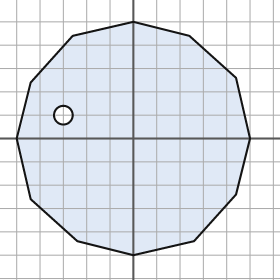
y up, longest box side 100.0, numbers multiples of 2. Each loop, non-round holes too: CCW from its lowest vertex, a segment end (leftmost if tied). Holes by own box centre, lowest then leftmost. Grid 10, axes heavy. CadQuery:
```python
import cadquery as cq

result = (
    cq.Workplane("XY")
    .moveTo(0.0, -50.0)
    .lineTo(26.0, -44.0)
    .lineTo(44.0, -24.0)
    .lineTo(50.0, 0.0)
    .lineTo(44.0, 26.0)
    .lineTo(24.0, 44.0)
    .lineTo(0.0, 50.0)
    .lineTo(-26.0, 44.0)
    .lineTo(-44.0, 24.0)
    .lineTo(-50.0, 0.0)
    .lineTo(-44.0, -26.0)
    .lineTo(-24.0, -44.0)
    .close()
    .moveTo(-30.0, 10.0)
    .circle(4.0)
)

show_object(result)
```